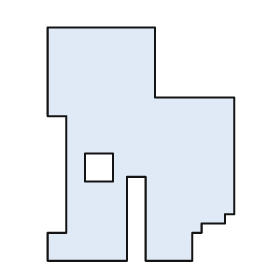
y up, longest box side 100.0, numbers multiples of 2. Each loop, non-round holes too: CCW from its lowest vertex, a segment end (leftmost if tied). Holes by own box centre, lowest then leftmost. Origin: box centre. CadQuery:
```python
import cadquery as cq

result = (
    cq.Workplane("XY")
    .moveTo(-40.0, -50.0)
    .lineTo(-6.0, -50.0)
    .lineTo(-6.0, -14.0)
    .lineTo(2.0, -14.0)
    .lineTo(2.0, -50.0)
    .lineTo(22.0, -50.0)
    .lineTo(22.0, -38.0)
    .lineTo(26.0, -38.0)
    .lineTo(26.0, -34.0)
    .lineTo(36.0, -34.0)
    .lineTo(36.0, -30.0)
    .lineTo(40.0, -30.0)
    .lineTo(40.0, 20.0)
    .lineTo(6.0, 20.0)
    .lineTo(6.0, 50.0)
    .lineTo(-40.0, 50.0)
    .lineTo(-40.0, 12.0)
    .lineTo(-32.0, 12.0)
    .lineTo(-32.0, -38.0)
    .lineTo(-40.0, -38.0)
    .close()
    .moveTo(-24.0, -16.0)
    .lineTo(-12.0, -16.0)
    .lineTo(-12.0, -4.0)
    .lineTo(-24.0, -4.0)
    .close()
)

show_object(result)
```